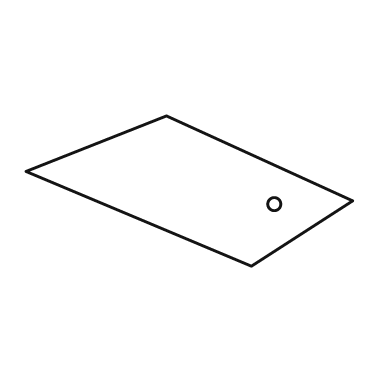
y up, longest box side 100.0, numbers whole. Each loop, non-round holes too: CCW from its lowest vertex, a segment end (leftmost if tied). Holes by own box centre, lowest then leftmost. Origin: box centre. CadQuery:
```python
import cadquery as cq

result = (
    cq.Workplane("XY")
    .moveTo(19.0, -23.0)
    .lineTo(50.0, -3.0)
    .lineTo(-7.0, 23.0)
    .lineTo(-50.0, 6.0)
    .close()
    .moveTo(26.0, -4.0)
    .circle(2.0)
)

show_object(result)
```